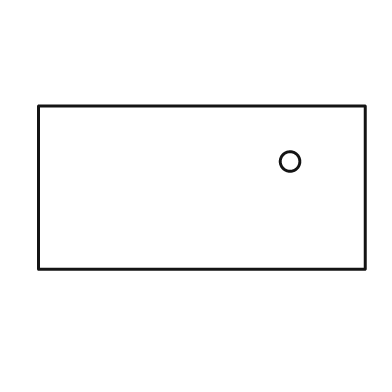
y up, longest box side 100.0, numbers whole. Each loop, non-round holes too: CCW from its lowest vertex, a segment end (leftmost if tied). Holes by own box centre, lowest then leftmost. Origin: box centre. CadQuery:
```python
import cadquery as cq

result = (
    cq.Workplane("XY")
    .moveTo(-50.0, -25.0)
    .lineTo(50.0, -25.0)
    .lineTo(50.0, 25.0)
    .lineTo(-50.0, 25.0)
    .close()
    .moveTo(27.0, 8.0)
    .circle(3.0)
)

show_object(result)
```